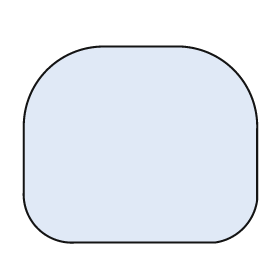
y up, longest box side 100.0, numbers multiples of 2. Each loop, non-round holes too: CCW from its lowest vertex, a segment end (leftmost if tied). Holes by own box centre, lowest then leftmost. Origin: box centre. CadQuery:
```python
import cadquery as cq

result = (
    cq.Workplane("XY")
    .moveTo(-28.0, -42.0)
    .lineTo(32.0, -42.0)
    .threePointArc((44.0, -36.0), (50.0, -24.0))
    .lineTo(50.0, 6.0)
    .threePointArc((40.0, 32.0), (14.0, 42.0))
    .lineTo(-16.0, 42.0)
    .threePointArc((-40.0, 32.0), (-50.0, 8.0))
    .lineTo(-50.0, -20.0)
    .threePointArc((-44.0, -36.0), (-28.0, -42.0))
    .close()
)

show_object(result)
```